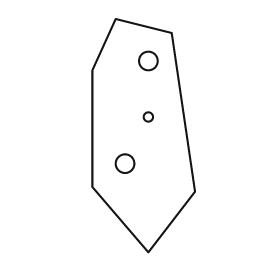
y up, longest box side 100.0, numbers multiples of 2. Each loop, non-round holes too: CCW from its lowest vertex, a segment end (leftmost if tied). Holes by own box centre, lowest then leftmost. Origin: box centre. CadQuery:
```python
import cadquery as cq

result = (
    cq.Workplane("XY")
    .moveTo(2.0, -50.0)
    .lineTo(22.0, -24.0)
    .lineTo(12.0, 44.0)
    .lineTo(-12.0, 50.0)
    .lineTo(-22.0, 28.0)
    .lineTo(-22.0, -22.0)
    .close()
    .moveTo(-8.0, -12.0)
    .circle(4.0)
    .moveTo(2.0, 8.0)
    .circle(2.0)
    .moveTo(2.0, 32.0)
    .circle(4.0)
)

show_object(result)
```